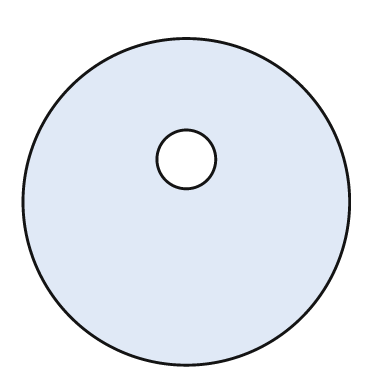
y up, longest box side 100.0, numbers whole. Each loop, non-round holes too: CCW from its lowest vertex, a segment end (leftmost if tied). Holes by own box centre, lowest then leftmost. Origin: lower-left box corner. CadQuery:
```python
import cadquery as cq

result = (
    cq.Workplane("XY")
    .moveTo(50.0, 50.0)
    .circle(50.0)
    .moveTo(50.0, 63.0)
    .circle(9.0)
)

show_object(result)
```